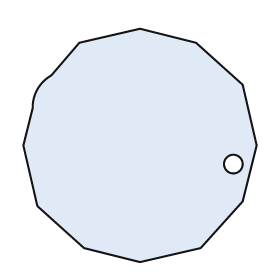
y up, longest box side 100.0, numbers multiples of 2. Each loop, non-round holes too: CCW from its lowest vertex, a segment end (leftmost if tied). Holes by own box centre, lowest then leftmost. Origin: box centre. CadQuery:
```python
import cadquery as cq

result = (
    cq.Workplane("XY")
    .moveTo(0.0, -50.0)
    .lineTo(26.0, -44.0)
    .lineTo(44.0, -24.0)
    .lineTo(50.0, 0.0)
    .lineTo(44.0, 26.0)
    .lineTo(24.0, 44.0)
    .lineTo(0.0, 50.0)
    .lineTo(-26.0, 44.0)
    .lineTo(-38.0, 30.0)
    .threePointArc((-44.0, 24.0), (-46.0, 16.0))
    .lineTo(-50.0, 0.0)
    .lineTo(-44.0, -26.0)
    .lineTo(-24.0, -44.0)
    .close()
    .moveTo(40.0, -8.0)
    .circle(4.0)
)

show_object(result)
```